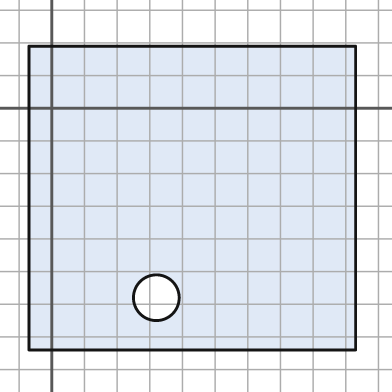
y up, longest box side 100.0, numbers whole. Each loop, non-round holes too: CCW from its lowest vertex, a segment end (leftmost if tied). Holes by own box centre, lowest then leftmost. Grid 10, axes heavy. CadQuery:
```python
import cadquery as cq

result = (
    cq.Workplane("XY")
    .moveTo(-7.0, -74.0)
    .lineTo(93.0, -74.0)
    .lineTo(93.0, 19.0)
    .lineTo(-7.0, 19.0)
    .close()
    .moveTo(32.0, -58.0)
    .circle(7.0)
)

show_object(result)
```